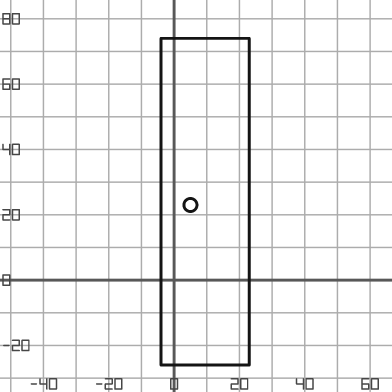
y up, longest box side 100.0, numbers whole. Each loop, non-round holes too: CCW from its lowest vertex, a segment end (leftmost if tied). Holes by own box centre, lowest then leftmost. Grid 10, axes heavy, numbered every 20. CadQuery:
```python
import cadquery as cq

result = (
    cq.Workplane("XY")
    .moveTo(-4.0, -26.0)
    .lineTo(23.0, -26.0)
    .lineTo(23.0, 74.0)
    .lineTo(-4.0, 74.0)
    .close()
    .moveTo(5.0, 23.0)
    .circle(2.0)
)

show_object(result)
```